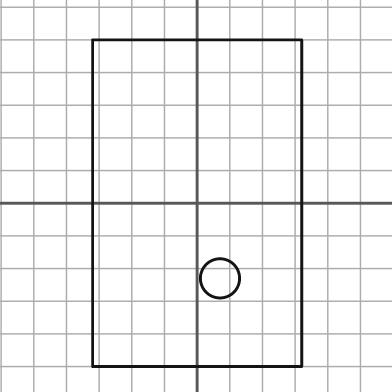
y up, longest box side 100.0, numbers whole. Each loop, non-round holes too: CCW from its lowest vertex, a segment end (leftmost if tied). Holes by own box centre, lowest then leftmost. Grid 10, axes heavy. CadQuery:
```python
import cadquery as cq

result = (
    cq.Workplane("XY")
    .moveTo(-32.0, -50.0)
    .lineTo(32.0, -50.0)
    .lineTo(32.0, 50.0)
    .lineTo(-32.0, 50.0)
    .close()
    .moveTo(7.0, -23.0)
    .circle(6.0)
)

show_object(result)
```